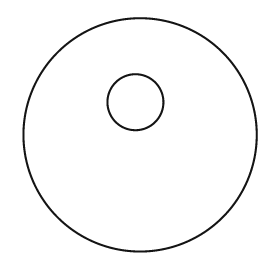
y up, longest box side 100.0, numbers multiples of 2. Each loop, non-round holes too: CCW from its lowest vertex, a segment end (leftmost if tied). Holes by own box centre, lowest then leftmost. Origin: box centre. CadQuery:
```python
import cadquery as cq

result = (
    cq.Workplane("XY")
    .moveTo(0.0, 0.0)
    .circle(50.0)
    .moveTo(-2.0, 14.0)
    .circle(12.0)
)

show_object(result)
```